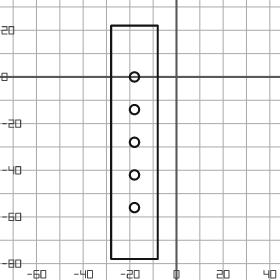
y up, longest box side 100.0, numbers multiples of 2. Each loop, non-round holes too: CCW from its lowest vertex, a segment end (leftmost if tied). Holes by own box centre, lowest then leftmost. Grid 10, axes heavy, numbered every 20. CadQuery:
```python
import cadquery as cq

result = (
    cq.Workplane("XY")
    .moveTo(-28.0, -78.0)
    .lineTo(-8.0, -78.0)
    .lineTo(-8.0, 22.0)
    .lineTo(-28.0, 22.0)
    .close()
    .moveTo(-18.0, -56.0)
    .circle(2.0)
    .moveTo(-18.0, -42.0)
    .circle(2.0)
    .moveTo(-18.0, -28.0)
    .circle(2.0)
    .moveTo(-18.0, -14.0)
    .circle(2.0)
    .moveTo(-18.0, 0.0)
    .circle(2.0)
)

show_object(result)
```